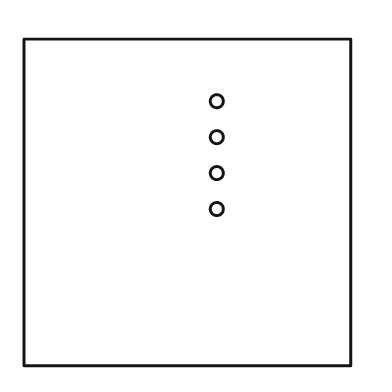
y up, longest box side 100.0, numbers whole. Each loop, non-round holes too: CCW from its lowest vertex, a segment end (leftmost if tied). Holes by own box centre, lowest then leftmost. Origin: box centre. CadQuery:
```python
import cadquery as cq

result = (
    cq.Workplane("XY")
    .moveTo(-50.0, -50.0)
    .lineTo(50.0, -50.0)
    .lineTo(50.0, 50.0)
    .lineTo(-50.0, 50.0)
    .close()
    .moveTo(9.0, -2.0)
    .circle(2.0)
    .moveTo(9.0, 9.0)
    .circle(2.0)
    .moveTo(9.0, 20.0)
    .circle(2.0)
    .moveTo(9.0, 31.0)
    .circle(2.0)
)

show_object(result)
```